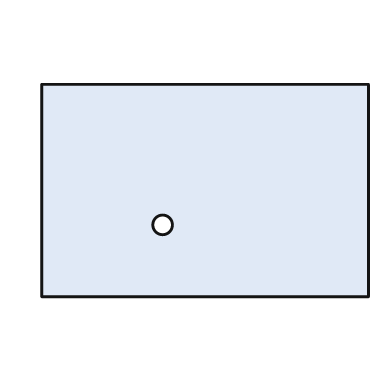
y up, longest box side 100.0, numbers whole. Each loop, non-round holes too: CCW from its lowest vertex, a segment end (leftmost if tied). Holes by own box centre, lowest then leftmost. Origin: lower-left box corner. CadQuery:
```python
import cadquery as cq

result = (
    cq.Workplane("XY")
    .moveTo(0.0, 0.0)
    .lineTo(100.0, 0.0)
    .lineTo(100.0, 65.0)
    .lineTo(0.0, 65.0)
    .close()
    .moveTo(37.0, 22.0)
    .circle(3.0)
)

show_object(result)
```